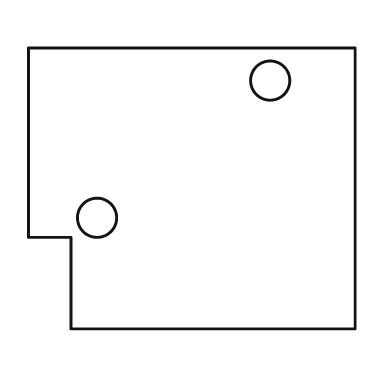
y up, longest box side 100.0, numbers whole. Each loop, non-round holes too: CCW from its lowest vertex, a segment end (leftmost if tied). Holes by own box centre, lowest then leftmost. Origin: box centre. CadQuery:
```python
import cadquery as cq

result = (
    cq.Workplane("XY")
    .moveTo(-37.0, -43.0)
    .lineTo(50.0, -43.0)
    .lineTo(50.0, 43.0)
    .lineTo(-50.0, 43.0)
    .lineTo(-50.0, -15.0)
    .lineTo(-37.0, -15.0)
    .close()
    .moveTo(-29.0, -9.0)
    .circle(6.0)
    .moveTo(24.0, 33.0)
    .circle(6.0)
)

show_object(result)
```